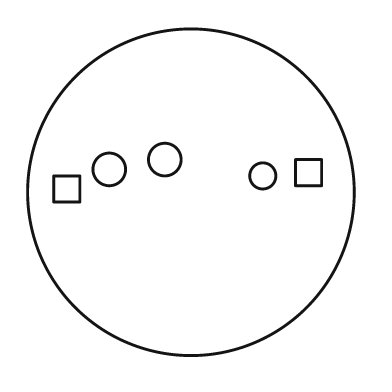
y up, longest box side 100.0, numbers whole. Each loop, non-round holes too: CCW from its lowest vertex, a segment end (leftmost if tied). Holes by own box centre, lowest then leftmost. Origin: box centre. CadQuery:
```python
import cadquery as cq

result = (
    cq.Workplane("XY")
    .moveTo(0.0, 0.0)
    .circle(50.0)
    .moveTo(-42.0, -3.0)
    .lineTo(-34.0, -3.0)
    .lineTo(-34.0, 5.0)
    .lineTo(-42.0, 5.0)
    .close()
    .moveTo(22.0, 5.0)
    .circle(4.0)
    .moveTo(32.0, 2.0)
    .lineTo(40.0, 2.0)
    .lineTo(40.0, 10.0)
    .lineTo(32.0, 10.0)
    .close()
    .moveTo(-25.0, 7.0)
    .circle(5.0)
    .moveTo(-8.0, 10.0)
    .circle(5.0)
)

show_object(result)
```